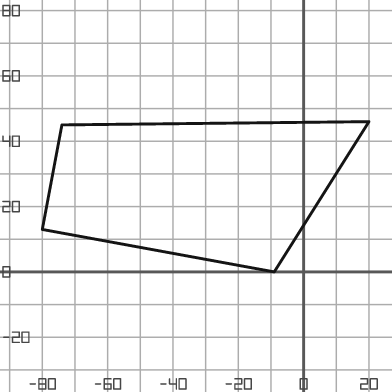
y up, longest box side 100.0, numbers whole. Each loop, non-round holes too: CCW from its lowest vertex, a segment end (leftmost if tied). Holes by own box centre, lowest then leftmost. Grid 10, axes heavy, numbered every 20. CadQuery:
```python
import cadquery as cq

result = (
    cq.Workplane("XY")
    .moveTo(-9.0, 0.0)
    .lineTo(20.0, 46.0)
    .lineTo(-74.0, 45.0)
    .lineTo(-80.0, 13.0)
    .close()
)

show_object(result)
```